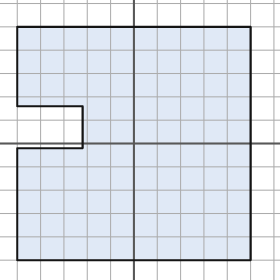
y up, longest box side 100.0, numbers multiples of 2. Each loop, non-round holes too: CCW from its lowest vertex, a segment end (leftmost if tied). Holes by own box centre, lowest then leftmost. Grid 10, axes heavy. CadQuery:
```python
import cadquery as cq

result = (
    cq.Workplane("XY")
    .moveTo(-50.0, -50.0)
    .lineTo(50.0, -50.0)
    .lineTo(50.0, 50.0)
    .lineTo(-50.0, 50.0)
    .lineTo(-50.0, 16.0)
    .lineTo(-22.0, 16.0)
    .lineTo(-22.0, -2.0)
    .lineTo(-50.0, -2.0)
    .close()
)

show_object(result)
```